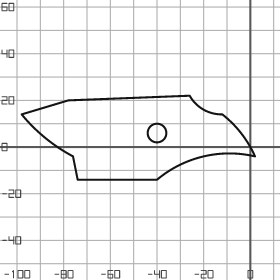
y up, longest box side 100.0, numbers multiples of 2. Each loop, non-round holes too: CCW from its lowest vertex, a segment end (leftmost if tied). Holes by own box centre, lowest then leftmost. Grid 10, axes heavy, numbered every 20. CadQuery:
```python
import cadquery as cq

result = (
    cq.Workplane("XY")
    .moveTo(-74.0, -14.0)
    .lineTo(-40.0, -14.0)
    .threePointArc((-20.0, -4.0), (2.0, -4.0))
    .threePointArc((-4.0, 6.0), (-12.0, 14.0))
    .threePointArc((-20.0, 16.0), (-26.0, 22.0))
    .lineTo(-78.0, 20.0)
    .lineTo(-98.0, 14.0)
    .threePointArc((-88.0, 4.0), (-76.0, -4.0))
    .close()
    .moveTo(-40.0, 6.0)
    .circle(4.0)
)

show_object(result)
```